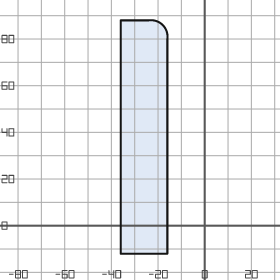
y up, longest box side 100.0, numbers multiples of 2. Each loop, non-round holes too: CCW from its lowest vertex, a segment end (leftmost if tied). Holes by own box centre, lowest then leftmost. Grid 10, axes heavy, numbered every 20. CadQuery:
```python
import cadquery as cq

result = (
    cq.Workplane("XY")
    .moveTo(-36.0, -12.0)
    .lineTo(-16.0, -12.0)
    .lineTo(-16.0, 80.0)
    .threePointArc((-18.0, 86.0), (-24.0, 88.0))
    .lineTo(-36.0, 88.0)
    .close()
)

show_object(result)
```